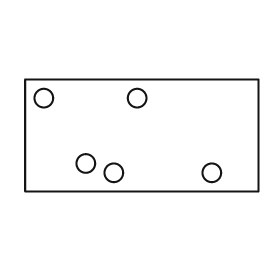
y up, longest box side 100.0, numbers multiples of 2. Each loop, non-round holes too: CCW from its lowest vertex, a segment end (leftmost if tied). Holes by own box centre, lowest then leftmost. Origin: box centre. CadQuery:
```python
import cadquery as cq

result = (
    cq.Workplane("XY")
    .moveTo(-50.0, -24.0)
    .lineTo(50.0, -24.0)
    .lineTo(50.0, 24.0)
    .lineTo(-50.0, 24.0)
    .close()
    .moveTo(-12.0, -16.0)
    .circle(4.0)
    .moveTo(30.0, -16.0)
    .circle(4.0)
    .moveTo(-24.0, -12.0)
    .circle(4.0)
    .moveTo(-42.0, 16.0)
    .circle(4.0)
    .moveTo(-2.0, 16.0)
    .circle(4.0)
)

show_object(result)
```